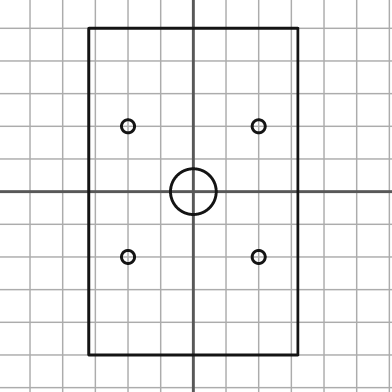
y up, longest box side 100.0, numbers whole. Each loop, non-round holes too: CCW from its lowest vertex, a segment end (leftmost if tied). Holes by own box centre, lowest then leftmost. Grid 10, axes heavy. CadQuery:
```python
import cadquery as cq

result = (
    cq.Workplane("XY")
    .moveTo(-32.0, -50.0)
    .lineTo(32.0, -50.0)
    .lineTo(32.0, 50.0)
    .lineTo(-32.0, 50.0)
    .close()
    .moveTo(-20.0, -20.0)
    .circle(2.0)
    .moveTo(20.0, -20.0)
    .circle(2.0)
    .moveTo(0.0, 0.0)
    .circle(7.0)
    .moveTo(-20.0, 20.0)
    .circle(2.0)
    .moveTo(20.0, 20.0)
    .circle(2.0)
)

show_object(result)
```